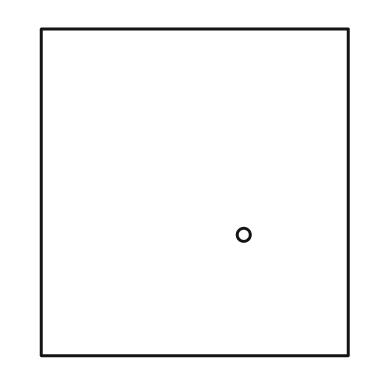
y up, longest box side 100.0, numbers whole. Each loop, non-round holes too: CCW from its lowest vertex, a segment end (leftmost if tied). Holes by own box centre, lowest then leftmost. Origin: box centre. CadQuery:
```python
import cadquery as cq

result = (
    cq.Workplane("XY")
    .moveTo(-47.0, -50.0)
    .lineTo(47.0, -50.0)
    .lineTo(47.0, 50.0)
    .lineTo(-47.0, 50.0)
    .close()
    .moveTo(15.0, -13.0)
    .circle(2.0)
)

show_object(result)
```